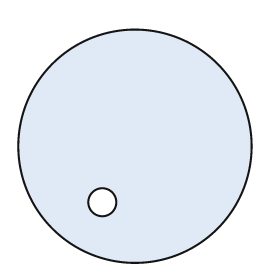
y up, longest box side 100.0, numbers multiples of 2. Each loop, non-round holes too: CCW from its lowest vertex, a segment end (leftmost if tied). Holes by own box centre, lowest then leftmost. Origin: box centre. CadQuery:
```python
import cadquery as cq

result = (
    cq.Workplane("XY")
    .moveTo(0.0, 0.0)
    .circle(50.0)
    .moveTo(-14.0, -24.0)
    .circle(6.0)
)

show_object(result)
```